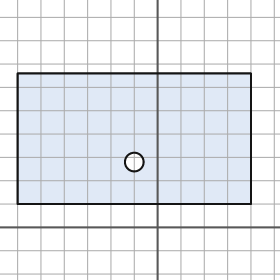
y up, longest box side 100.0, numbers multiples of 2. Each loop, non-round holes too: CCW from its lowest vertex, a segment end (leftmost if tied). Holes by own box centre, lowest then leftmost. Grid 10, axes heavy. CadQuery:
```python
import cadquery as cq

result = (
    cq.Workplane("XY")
    .moveTo(-60.0, 10.0)
    .lineTo(40.0, 10.0)
    .lineTo(40.0, 66.0)
    .lineTo(-60.0, 66.0)
    .close()
    .moveTo(-10.0, 28.0)
    .circle(4.0)
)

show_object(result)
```